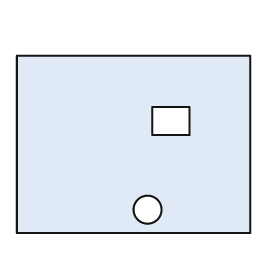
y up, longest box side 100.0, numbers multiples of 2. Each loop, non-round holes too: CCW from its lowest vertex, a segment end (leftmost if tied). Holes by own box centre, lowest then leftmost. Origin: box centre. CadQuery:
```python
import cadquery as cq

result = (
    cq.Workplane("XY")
    .moveTo(-50.0, -38.0)
    .lineTo(50.0, -38.0)
    .lineTo(50.0, 38.0)
    .lineTo(-50.0, 38.0)
    .close()
    .moveTo(6.0, -28.0)
    .circle(6.0)
    .moveTo(8.0, 4.0)
    .lineTo(24.0, 4.0)
    .lineTo(24.0, 16.0)
    .lineTo(8.0, 16.0)
    .close()
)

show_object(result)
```